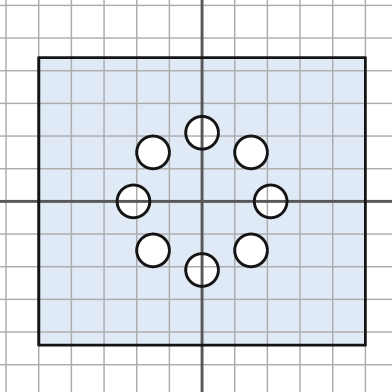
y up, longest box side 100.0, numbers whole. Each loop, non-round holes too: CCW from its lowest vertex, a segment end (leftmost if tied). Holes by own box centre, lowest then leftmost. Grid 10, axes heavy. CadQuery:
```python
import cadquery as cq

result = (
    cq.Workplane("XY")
    .moveTo(-50.0, -44.0)
    .lineTo(50.0, -44.0)
    .lineTo(50.0, 44.0)
    .lineTo(-50.0, 44.0)
    .close()
    .moveTo(0.0, -21.0)
    .circle(5.0)
    .moveTo(-15.0, -15.0)
    .circle(5.0)
    .moveTo(15.0, -15.0)
    .circle(5.0)
    .moveTo(-21.0, 0.0)
    .circle(5.0)
    .moveTo(21.0, 0.0)
    .circle(5.0)
    .moveTo(-15.0, 15.0)
    .circle(5.0)
    .moveTo(15.0, 15.0)
    .circle(5.0)
    .moveTo(0.0, 21.0)
    .circle(5.0)
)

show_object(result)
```